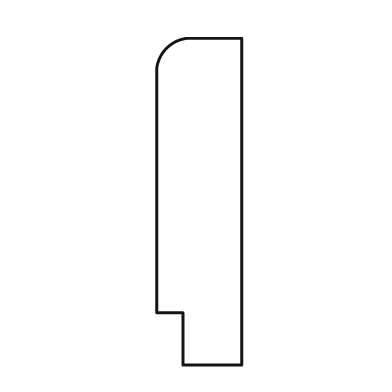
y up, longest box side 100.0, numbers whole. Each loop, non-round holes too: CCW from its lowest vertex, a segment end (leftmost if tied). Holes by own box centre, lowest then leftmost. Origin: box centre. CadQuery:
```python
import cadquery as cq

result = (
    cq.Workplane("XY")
    .moveTo(-5.0, -50.0)
    .lineTo(13.0, -50.0)
    .lineTo(13.0, 50.0)
    .lineTo(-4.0, 50.0)
    .threePointArc((-10.0, 47.0), (-13.0, 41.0))
    .lineTo(-13.0, -34.0)
    .lineTo(-5.0, -34.0)
    .close()
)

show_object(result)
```